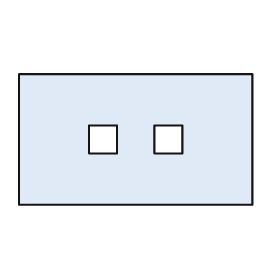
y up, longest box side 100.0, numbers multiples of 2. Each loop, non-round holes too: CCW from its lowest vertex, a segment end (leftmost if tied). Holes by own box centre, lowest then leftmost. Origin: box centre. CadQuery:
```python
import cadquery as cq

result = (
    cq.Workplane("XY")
    .moveTo(-50.0, -28.0)
    .lineTo(50.0, -28.0)
    .lineTo(50.0, 28.0)
    .lineTo(-50.0, 28.0)
    .close()
    .moveTo(-20.0, -6.0)
    .lineTo(-8.0, -6.0)
    .lineTo(-8.0, 6.0)
    .lineTo(-20.0, 6.0)
    .close()
    .moveTo(8.0, -6.0)
    .lineTo(20.0, -6.0)
    .lineTo(20.0, 6.0)
    .lineTo(8.0, 6.0)
    .close()
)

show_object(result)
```